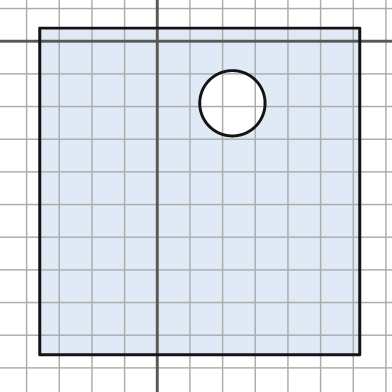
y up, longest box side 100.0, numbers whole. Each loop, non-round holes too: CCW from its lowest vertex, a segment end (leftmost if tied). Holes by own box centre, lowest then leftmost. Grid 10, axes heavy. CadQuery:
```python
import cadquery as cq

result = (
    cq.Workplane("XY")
    .moveTo(-36.0, -96.0)
    .lineTo(62.0, -96.0)
    .lineTo(62.0, 4.0)
    .lineTo(-36.0, 4.0)
    .close()
    .moveTo(23.0, -19.0)
    .circle(10.0)
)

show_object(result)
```